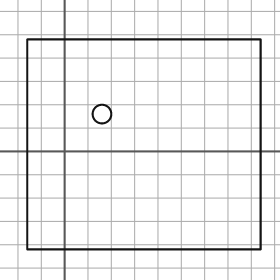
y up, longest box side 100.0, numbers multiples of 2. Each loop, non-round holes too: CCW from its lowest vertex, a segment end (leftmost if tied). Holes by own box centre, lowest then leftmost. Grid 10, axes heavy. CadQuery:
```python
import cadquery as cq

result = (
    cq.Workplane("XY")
    .moveTo(-16.0, -42.0)
    .lineTo(84.0, -42.0)
    .lineTo(84.0, 48.0)
    .lineTo(-16.0, 48.0)
    .close()
    .moveTo(16.0, 16.0)
    .circle(4.0)
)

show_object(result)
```